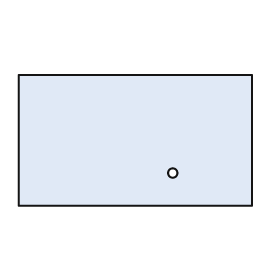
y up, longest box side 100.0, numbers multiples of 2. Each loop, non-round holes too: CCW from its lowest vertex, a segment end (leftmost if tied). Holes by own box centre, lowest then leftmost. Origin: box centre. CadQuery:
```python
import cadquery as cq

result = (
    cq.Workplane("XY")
    .moveTo(-50.0, -28.0)
    .lineTo(50.0, -28.0)
    .lineTo(50.0, 28.0)
    .lineTo(-50.0, 28.0)
    .close()
    .moveTo(16.0, -14.0)
    .circle(2.0)
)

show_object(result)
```